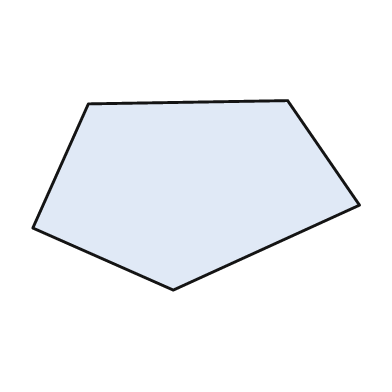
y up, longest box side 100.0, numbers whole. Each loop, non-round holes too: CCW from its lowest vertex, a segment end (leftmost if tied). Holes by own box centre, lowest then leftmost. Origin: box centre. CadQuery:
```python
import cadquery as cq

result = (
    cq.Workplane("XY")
    .moveTo(-7.0, -29.0)
    .lineTo(50.0, -3.0)
    .lineTo(28.0, 29.0)
    .lineTo(-33.0, 28.0)
    .lineTo(-50.0, -10.0)
    .close()
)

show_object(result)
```